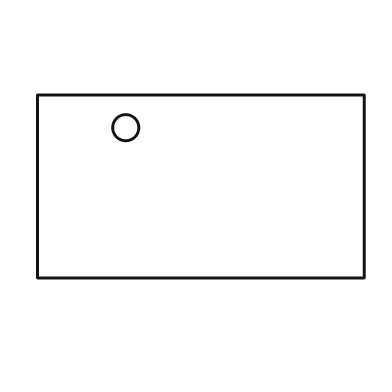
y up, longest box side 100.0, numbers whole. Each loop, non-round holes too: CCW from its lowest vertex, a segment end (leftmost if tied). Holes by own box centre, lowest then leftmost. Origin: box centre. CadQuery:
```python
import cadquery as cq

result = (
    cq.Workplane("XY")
    .moveTo(-50.0, -28.0)
    .lineTo(50.0, -28.0)
    .lineTo(50.0, 28.0)
    .lineTo(-50.0, 28.0)
    .close()
    .moveTo(-23.0, 18.0)
    .circle(4.0)
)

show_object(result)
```